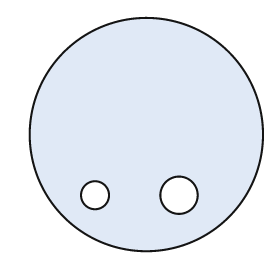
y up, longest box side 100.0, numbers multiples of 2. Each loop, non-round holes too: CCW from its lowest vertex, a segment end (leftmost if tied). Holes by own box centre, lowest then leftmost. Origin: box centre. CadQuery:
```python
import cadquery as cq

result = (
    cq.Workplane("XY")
    .moveTo(0.0, 0.0)
    .circle(50.0)
    .moveTo(-22.0, -26.0)
    .circle(6.0)
    .moveTo(14.0, -26.0)
    .circle(8.0)
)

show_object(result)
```